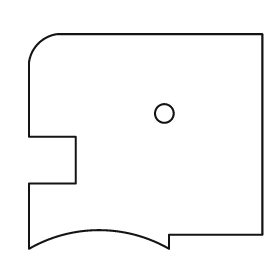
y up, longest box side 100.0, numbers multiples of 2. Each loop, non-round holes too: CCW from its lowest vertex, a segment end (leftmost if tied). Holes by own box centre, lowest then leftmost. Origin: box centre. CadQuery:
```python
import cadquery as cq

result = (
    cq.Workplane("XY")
    .moveTo(-50.0, -46.0)
    .threePointArc((-20.0, -38.0), (10.0, -46.0))
    .lineTo(10.0, -40.0)
    .lineTo(50.0, -40.0)
    .lineTo(50.0, 46.0)
    .lineTo(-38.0, 46.0)
    .threePointArc((-46.0, 42.0), (-50.0, 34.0))
    .lineTo(-50.0, 2.0)
    .lineTo(-30.0, 2.0)
    .lineTo(-30.0, -18.0)
    .lineTo(-50.0, -18.0)
    .close()
    .moveTo(8.0, 12.0)
    .circle(4.0)
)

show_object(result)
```